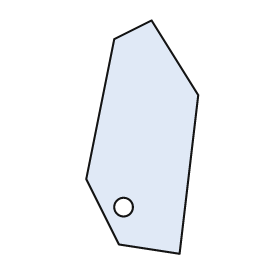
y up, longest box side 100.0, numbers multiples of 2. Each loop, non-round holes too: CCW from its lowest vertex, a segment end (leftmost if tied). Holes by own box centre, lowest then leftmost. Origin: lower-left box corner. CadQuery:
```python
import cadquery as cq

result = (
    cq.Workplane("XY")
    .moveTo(40.0, 0.0)
    .lineTo(48.0, 68.0)
    .lineTo(28.0, 100.0)
    .lineTo(12.0, 92.0)
    .lineTo(0.0, 32.0)
    .lineTo(14.0, 4.0)
    .close()
    .moveTo(16.0, 20.0)
    .circle(4.0)
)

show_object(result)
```